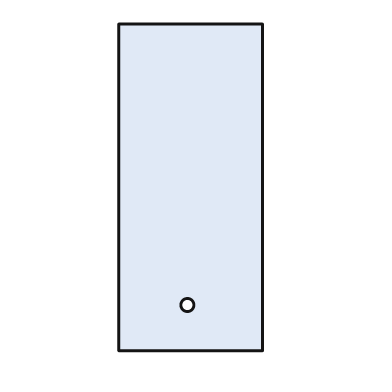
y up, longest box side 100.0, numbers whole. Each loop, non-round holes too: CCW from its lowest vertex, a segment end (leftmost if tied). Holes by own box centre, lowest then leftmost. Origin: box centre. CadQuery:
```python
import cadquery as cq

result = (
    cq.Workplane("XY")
    .moveTo(-22.0, -50.0)
    .lineTo(22.0, -50.0)
    .lineTo(22.0, 50.0)
    .lineTo(-22.0, 50.0)
    .close()
    .moveTo(-1.0, -36.0)
    .circle(2.0)
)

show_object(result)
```